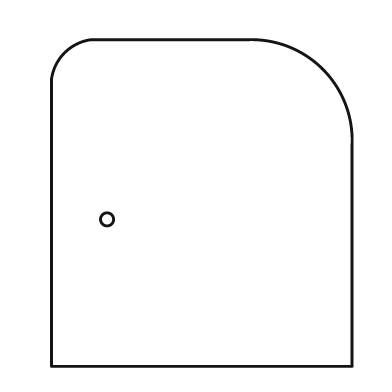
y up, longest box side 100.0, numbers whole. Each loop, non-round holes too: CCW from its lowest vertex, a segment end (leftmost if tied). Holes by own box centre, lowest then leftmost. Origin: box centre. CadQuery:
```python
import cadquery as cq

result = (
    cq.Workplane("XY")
    .moveTo(-46.0, -50.0)
    .lineTo(46.0, -50.0)
    .lineTo(46.0, 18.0)
    .threePointArc((37.0, 41.0), (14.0, 50.0))
    .lineTo(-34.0, 50.0)
    .threePointArc((-42.0, 46.0), (-46.0, 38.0))
    .close()
    .moveTo(-29.0, -5.0)
    .circle(2.0)
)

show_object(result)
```